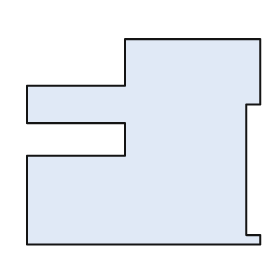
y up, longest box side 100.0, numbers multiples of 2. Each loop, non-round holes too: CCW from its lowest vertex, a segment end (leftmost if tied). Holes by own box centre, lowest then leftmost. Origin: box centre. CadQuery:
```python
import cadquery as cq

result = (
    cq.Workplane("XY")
    .moveTo(-50.0, -44.0)
    .lineTo(50.0, -44.0)
    .lineTo(50.0, -40.0)
    .lineTo(44.0, -40.0)
    .lineTo(44.0, 16.0)
    .lineTo(50.0, 16.0)
    .lineTo(50.0, 44.0)
    .lineTo(-8.0, 44.0)
    .lineTo(-8.0, 24.0)
    .lineTo(-50.0, 24.0)
    .lineTo(-50.0, 8.0)
    .lineTo(-8.0, 8.0)
    .lineTo(-8.0, -6.0)
    .lineTo(-50.0, -6.0)
    .close()
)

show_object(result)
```